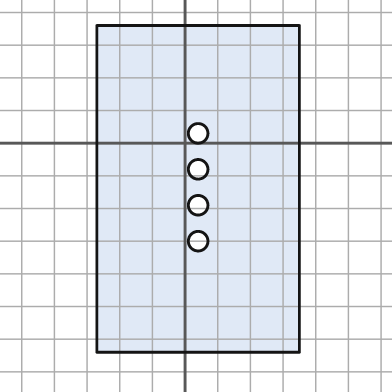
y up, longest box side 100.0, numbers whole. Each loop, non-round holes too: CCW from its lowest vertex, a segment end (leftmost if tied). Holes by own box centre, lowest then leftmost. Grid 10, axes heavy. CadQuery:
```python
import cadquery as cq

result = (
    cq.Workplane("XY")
    .moveTo(-27.0, -64.0)
    .lineTo(35.0, -64.0)
    .lineTo(35.0, 36.0)
    .lineTo(-27.0, 36.0)
    .close()
    .moveTo(4.0, -30.0)
    .circle(3.0)
    .moveTo(4.0, -19.0)
    .circle(3.0)
    .moveTo(4.0, -8.0)
    .circle(3.0)
    .moveTo(4.0, 3.0)
    .circle(3.0)
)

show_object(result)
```